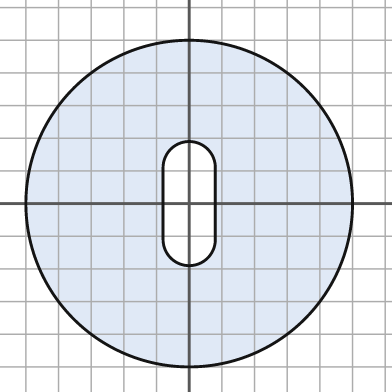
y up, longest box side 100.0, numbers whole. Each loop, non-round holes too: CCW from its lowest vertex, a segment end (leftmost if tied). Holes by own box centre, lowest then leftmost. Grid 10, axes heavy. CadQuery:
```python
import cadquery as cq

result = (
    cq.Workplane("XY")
    .moveTo(0.0, 0.0)
    .circle(50.0)
    .moveTo(-8.0, -11.0)
    .threePointArc((0.0, -19.0), (8.0, -11.0))
    .lineTo(8.0, 11.0)
    .threePointArc((0.0, 19.0), (-8.0, 11.0))
    .close()
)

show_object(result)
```